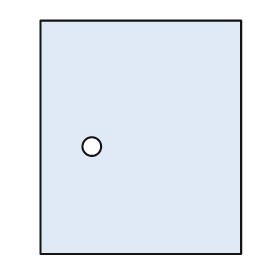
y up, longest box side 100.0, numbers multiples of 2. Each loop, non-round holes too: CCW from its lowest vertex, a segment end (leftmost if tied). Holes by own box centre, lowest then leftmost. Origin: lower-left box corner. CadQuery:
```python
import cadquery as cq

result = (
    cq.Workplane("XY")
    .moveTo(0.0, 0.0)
    .lineTo(86.0, 0.0)
    .lineTo(86.0, 100.0)
    .lineTo(0.0, 100.0)
    .close()
    .moveTo(22.0, 46.0)
    .circle(4.0)
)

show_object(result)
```